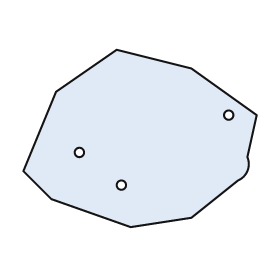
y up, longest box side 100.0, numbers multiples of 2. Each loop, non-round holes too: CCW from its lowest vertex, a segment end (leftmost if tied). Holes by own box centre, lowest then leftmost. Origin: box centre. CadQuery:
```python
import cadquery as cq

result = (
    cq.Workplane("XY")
    .moveTo(-4.0, -38.0)
    .lineTo(22.0, -34.0)
    .lineTo(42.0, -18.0)
    .threePointArc((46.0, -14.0), (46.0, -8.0))
    .lineTo(50.0, 10.0)
    .lineTo(22.0, 30.0)
    .lineTo(-10.0, 38.0)
    .lineTo(-36.0, 20.0)
    .lineTo(-50.0, -14.0)
    .lineTo(-38.0, -26.0)
    .close()
    .moveTo(-8.0, -20.0)
    .circle(2.0)
    .moveTo(-26.0, -6.0)
    .circle(2.0)
    .moveTo(38.0, 10.0)
    .circle(2.0)
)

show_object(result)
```